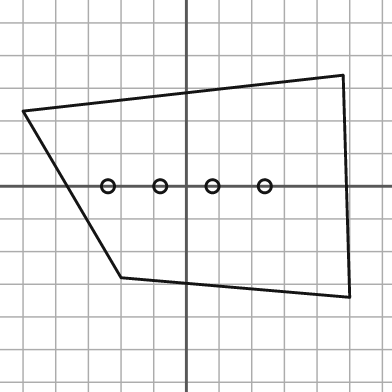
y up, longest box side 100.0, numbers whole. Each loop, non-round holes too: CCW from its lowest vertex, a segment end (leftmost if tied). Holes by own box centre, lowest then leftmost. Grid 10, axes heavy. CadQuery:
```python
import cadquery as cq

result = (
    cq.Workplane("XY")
    .moveTo(50.0, -34.0)
    .lineTo(48.0, 34.0)
    .lineTo(-50.0, 23.0)
    .lineTo(-20.0, -28.0)
    .close()
    .moveTo(-24.0, 0.0)
    .circle(2.0)
    .moveTo(-8.0, 0.0)
    .circle(2.0)
    .moveTo(8.0, 0.0)
    .circle(2.0)
    .moveTo(24.0, 0.0)
    .circle(2.0)
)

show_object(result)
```